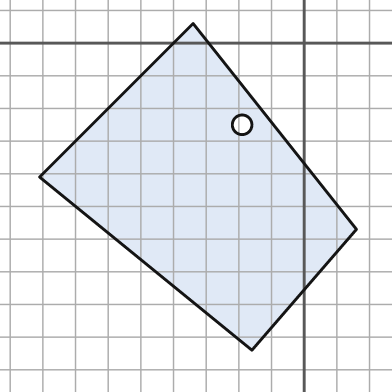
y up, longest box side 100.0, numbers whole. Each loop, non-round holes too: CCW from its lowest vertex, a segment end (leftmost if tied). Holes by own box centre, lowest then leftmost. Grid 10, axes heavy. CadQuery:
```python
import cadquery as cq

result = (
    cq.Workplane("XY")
    .moveTo(-16.0, -94.0)
    .lineTo(16.0, -57.0)
    .lineTo(-34.0, 6.0)
    .lineTo(-81.0, -41.0)
    .close()
    .moveTo(-19.0, -25.0)
    .circle(3.0)
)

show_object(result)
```